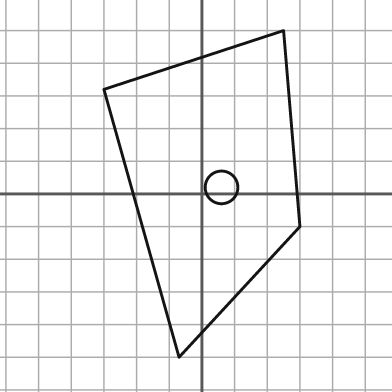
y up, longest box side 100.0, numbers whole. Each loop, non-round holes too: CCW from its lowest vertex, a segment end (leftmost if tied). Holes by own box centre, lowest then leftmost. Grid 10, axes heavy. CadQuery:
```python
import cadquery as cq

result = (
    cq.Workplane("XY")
    .moveTo(-7.0, -50.0)
    .lineTo(30.0, -10.0)
    .lineTo(25.0, 50.0)
    .lineTo(-30.0, 32.0)
    .close()
    .moveTo(6.0, 2.0)
    .circle(5.0)
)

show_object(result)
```